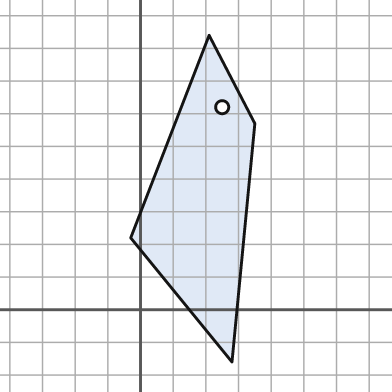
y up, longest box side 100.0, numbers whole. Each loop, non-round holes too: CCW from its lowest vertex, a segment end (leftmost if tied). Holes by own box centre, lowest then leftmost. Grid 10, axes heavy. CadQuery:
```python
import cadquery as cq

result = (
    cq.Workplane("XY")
    .moveTo(28.0, -16.0)
    .lineTo(35.0, 57.0)
    .lineTo(21.0, 84.0)
    .lineTo(-3.0, 22.0)
    .close()
    .moveTo(25.0, 62.0)
    .circle(2.0)
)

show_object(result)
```